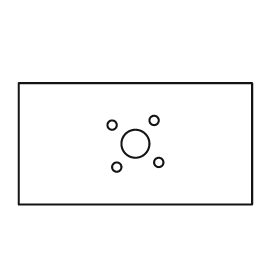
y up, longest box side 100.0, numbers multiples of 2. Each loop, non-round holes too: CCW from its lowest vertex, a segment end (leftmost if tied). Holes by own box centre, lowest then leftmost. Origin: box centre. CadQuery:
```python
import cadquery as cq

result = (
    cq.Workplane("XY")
    .moveTo(-50.0, -26.0)
    .lineTo(50.0, -26.0)
    .lineTo(50.0, 26.0)
    .lineTo(-50.0, 26.0)
    .close()
    .moveTo(-8.0, -10.0)
    .circle(2.0)
    .moveTo(10.0, -8.0)
    .circle(2.0)
    .moveTo(0.0, 0.0)
    .circle(6.0)
    .moveTo(-10.0, 8.0)
    .circle(2.0)
    .moveTo(8.0, 10.0)
    .circle(2.0)
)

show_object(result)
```